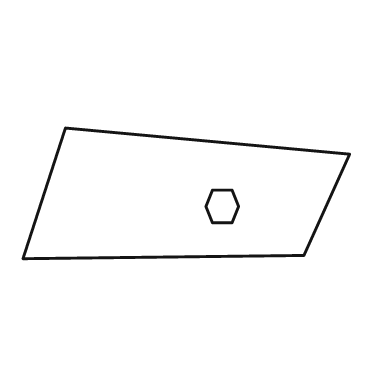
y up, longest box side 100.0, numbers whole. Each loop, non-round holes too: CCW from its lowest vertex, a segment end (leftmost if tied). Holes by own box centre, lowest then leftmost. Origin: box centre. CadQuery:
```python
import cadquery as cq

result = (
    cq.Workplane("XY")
    .moveTo(-50.0, -20.0)
    .lineTo(36.0, -19.0)
    .lineTo(50.0, 12.0)
    .lineTo(-37.0, 20.0)
    .close()
    .moveTo(8.0, -9.0)
    .lineTo(14.0, -9.0)
    .lineTo(16.0, -4.0)
    .lineTo(14.0, 1.0)
    .lineTo(8.0, 1.0)
    .lineTo(6.0, -4.0)
    .close()
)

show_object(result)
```